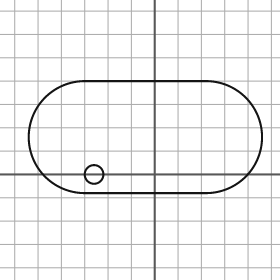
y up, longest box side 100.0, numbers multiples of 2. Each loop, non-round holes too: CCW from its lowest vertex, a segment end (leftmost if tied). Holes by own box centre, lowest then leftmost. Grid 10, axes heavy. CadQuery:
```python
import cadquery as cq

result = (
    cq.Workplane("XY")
    .moveTo(-30.0, -8.0)
    .lineTo(22.0, -8.0)
    .threePointArc((46.0, 16.0), (22.0, 40.0))
    .lineTo(-30.0, 40.0)
    .threePointArc((-54.0, 16.0), (-30.0, -8.0))
    .close()
    .moveTo(-26.0, 0.0)
    .circle(4.0)
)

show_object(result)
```